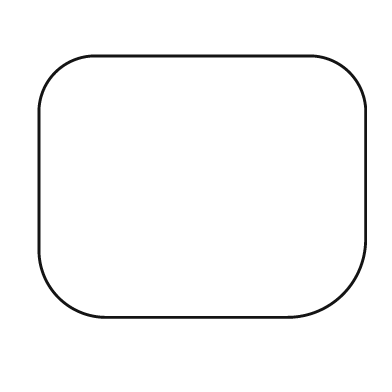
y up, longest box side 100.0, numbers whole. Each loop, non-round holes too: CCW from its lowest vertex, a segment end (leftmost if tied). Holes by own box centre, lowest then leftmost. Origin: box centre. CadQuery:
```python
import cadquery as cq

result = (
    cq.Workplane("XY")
    .moveTo(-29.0, -40.0)
    .lineTo(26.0, -40.0)
    .threePointArc((43.0, -33.0), (50.0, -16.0))
    .lineTo(50.0, 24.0)
    .threePointArc((45.0, 35.0), (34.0, 40.0))
    .lineTo(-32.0, 40.0)
    .threePointArc((-45.0, 35.0), (-50.0, 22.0))
    .lineTo(-50.0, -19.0)
    .threePointArc((-44.0, -34.0), (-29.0, -40.0))
    .close()
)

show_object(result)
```